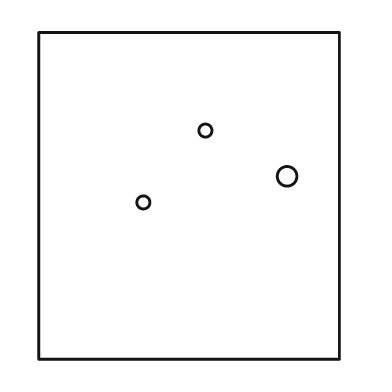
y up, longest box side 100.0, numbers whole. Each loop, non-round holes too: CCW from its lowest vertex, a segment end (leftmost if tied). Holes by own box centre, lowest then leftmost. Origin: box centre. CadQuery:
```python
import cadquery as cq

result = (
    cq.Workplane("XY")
    .moveTo(-46.0, -50.0)
    .lineTo(46.0, -50.0)
    .lineTo(46.0, 50.0)
    .lineTo(-46.0, 50.0)
    .close()
    .moveTo(-14.0, -2.0)
    .circle(2.0)
    .moveTo(30.0, 6.0)
    .circle(3.0)
    .moveTo(5.0, 20.0)
    .circle(2.0)
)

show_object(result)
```